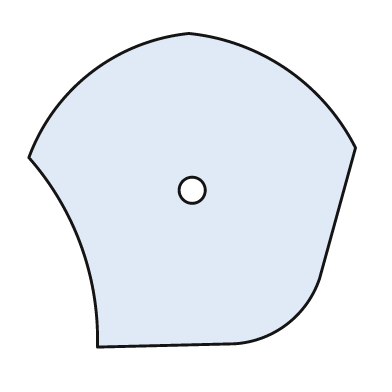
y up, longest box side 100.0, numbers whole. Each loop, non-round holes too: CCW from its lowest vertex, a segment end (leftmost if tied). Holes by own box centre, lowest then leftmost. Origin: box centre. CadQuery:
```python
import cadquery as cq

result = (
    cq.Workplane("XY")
    .moveTo(-29.0, -48.0)
    .lineTo(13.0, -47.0)
    .threePointArc((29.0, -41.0), (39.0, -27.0))
    .lineTo(50.0, 13.0)
    .threePointArc((29.0, 37.0), (-1.0, 48.0))
    .threePointArc((-31.0, 36.0), (-50.0, 10.0))
    .threePointArc((-34.0, -17.0), (-29.0, -48.0))
    .close()
    .moveTo(0.0, 0.0)
    .circle(4.0)
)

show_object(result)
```